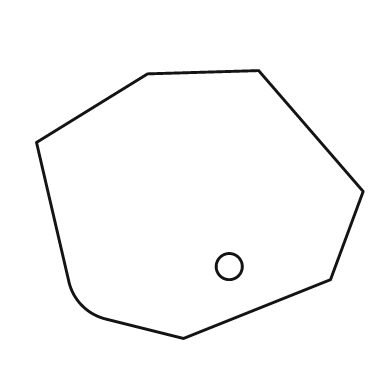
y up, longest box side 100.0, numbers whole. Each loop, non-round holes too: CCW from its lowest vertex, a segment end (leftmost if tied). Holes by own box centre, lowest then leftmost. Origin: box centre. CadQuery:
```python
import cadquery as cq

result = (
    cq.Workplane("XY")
    .moveTo(-5.0, -41.0)
    .lineTo(40.0, -23.0)
    .lineTo(50.0, 4.0)
    .lineTo(18.0, 41.0)
    .lineTo(-16.0, 40.0)
    .lineTo(-50.0, 19.0)
    .lineTo(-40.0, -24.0)
    .threePointArc((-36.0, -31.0), (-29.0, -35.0))
    .close()
    .moveTo(9.0, -19.0)
    .circle(4.0)
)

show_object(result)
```